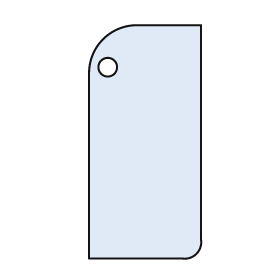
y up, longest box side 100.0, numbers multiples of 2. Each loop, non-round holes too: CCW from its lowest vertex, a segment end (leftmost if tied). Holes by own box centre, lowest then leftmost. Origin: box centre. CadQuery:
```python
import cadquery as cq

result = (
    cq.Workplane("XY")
    .moveTo(-24.0, -50.0)
    .lineTo(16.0, -50.0)
    .threePointArc((22.0, -48.0), (24.0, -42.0))
    .lineTo(24.0, 50.0)
    .lineTo(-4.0, 50.0)
    .threePointArc((-18.0, 44.0), (-24.0, 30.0))
    .close()
    .moveTo(-16.0, 32.0)
    .circle(4.0)
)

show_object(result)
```